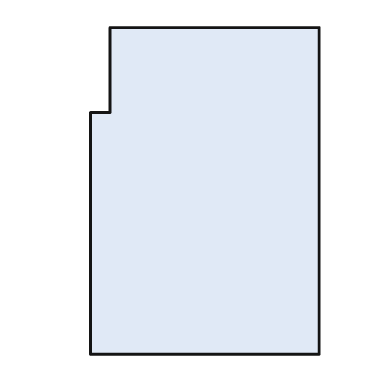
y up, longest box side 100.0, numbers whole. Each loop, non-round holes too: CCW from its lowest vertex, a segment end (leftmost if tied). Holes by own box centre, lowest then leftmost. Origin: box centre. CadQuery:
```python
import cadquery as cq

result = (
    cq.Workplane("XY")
    .moveTo(-35.0, -50.0)
    .lineTo(35.0, -50.0)
    .lineTo(35.0, 50.0)
    .lineTo(-29.0, 50.0)
    .lineTo(-29.0, 24.0)
    .lineTo(-35.0, 24.0)
    .close()
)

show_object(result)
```